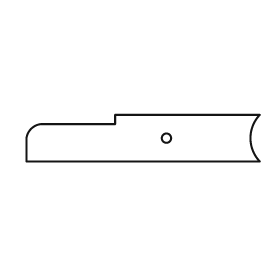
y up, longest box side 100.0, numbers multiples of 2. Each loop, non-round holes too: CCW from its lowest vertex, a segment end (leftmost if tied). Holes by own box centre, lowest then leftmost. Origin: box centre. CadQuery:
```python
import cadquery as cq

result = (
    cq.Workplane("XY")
    .moveTo(-50.0, -10.0)
    .lineTo(50.0, -10.0)
    .threePointArc((46.0, 0.0), (50.0, 10.0))
    .lineTo(-12.0, 10.0)
    .lineTo(-12.0, 6.0)
    .lineTo(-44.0, 6.0)
    .threePointArc((-48.0, 4.0), (-50.0, 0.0))
    .close()
    .moveTo(10.0, 0.0)
    .circle(2.0)
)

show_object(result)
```